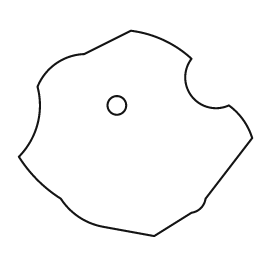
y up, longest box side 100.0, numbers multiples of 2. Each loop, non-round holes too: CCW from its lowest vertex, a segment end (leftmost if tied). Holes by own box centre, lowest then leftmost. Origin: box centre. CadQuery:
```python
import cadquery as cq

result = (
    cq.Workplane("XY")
    .moveTo(8.0, -44.0)
    .lineTo(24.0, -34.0)
    .threePointArc((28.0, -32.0), (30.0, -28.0))
    .lineTo(50.0, -2.0)
    .threePointArc((46.0, 6.0), (40.0, 12.0))
    .threePointArc((24.0, 16.0), (24.0, 32.0))
    .threePointArc((12.0, 40.0), (-2.0, 44.0))
    .lineTo(-22.0, 34.0)
    .threePointArc((-34.0, 30.0), (-42.0, 20.0))
    .threePointArc((-42.0, 4.0), (-50.0, -10.0))
    .threePointArc((-42.0, -20.0), (-32.0, -28.0))
    .threePointArc((-24.0, -36.0), (-14.0, -40.0))
    .close()
    .moveTo(-8.0, 12.0)
    .circle(4.0)
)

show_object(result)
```